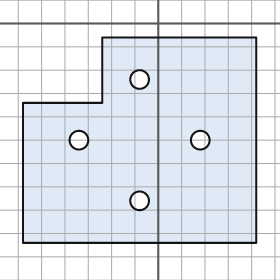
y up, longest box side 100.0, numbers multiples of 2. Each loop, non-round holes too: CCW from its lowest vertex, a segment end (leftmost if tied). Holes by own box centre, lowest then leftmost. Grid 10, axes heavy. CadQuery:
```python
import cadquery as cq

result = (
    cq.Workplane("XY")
    .moveTo(-58.0, -94.0)
    .lineTo(42.0, -94.0)
    .lineTo(42.0, -6.0)
    .lineTo(-24.0, -6.0)
    .lineTo(-24.0, -34.0)
    .lineTo(-58.0, -34.0)
    .close()
    .moveTo(-8.0, -76.0)
    .circle(4.0)
    .moveTo(-34.0, -50.0)
    .circle(4.0)
    .moveTo(18.0, -50.0)
    .circle(4.0)
    .moveTo(-8.0, -24.0)
    .circle(4.0)
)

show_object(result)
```